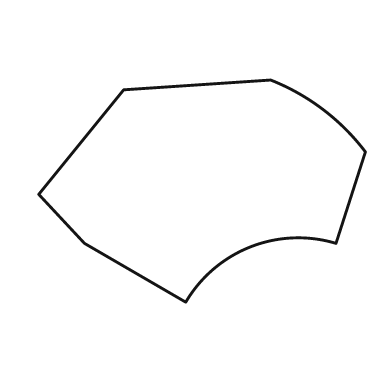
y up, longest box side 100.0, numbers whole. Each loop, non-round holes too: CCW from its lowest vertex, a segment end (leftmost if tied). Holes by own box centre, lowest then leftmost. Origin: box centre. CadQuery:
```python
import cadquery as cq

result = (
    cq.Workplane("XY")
    .moveTo(-5.0, -34.0)
    .threePointArc((15.0, -17.0), (41.0, -16.0))
    .lineTo(50.0, 12.0)
    .threePointArc((37.0, 25.0), (21.0, 34.0))
    .lineTo(-24.0, 31.0)
    .lineTo(-50.0, -1.0)
    .lineTo(-36.0, -16.0)
    .close()
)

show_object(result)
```